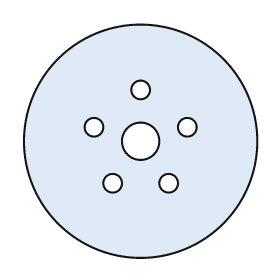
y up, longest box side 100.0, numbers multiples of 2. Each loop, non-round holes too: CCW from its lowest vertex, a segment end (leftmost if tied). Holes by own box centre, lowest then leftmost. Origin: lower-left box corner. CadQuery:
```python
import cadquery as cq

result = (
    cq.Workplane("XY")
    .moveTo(50.0, 50.0)
    .circle(50.0)
    .moveTo(38.0, 32.0)
    .circle(4.0)
    .moveTo(62.0, 32.0)
    .circle(4.0)
    .moveTo(50.0, 50.0)
    .circle(8.0)
    .moveTo(30.0, 56.0)
    .circle(4.0)
    .moveTo(70.0, 56.0)
    .circle(4.0)
    .moveTo(50.0, 72.0)
    .circle(4.0)
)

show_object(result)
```